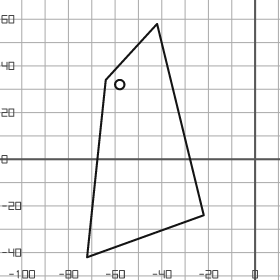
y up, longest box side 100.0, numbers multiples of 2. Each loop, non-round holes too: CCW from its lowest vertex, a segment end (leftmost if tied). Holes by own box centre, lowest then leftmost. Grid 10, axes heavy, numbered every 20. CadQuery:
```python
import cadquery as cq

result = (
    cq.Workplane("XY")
    .moveTo(-72.0, -42.0)
    .lineTo(-22.0, -24.0)
    .lineTo(-42.0, 58.0)
    .lineTo(-64.0, 34.0)
    .close()
    .moveTo(-58.0, 32.0)
    .circle(2.0)
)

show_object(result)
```